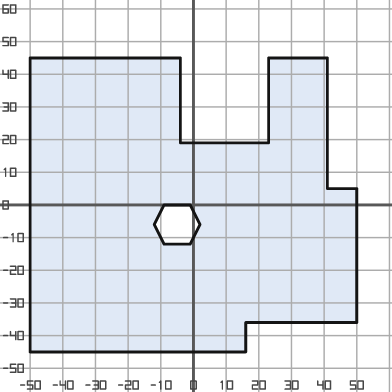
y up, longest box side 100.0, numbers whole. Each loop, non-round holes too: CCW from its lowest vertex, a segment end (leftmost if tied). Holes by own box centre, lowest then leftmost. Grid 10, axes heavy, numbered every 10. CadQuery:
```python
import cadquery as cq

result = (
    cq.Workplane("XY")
    .moveTo(-50.0, -45.0)
    .lineTo(16.0, -45.0)
    .lineTo(16.0, -36.0)
    .lineTo(50.0, -36.0)
    .lineTo(50.0, 5.0)
    .lineTo(41.0, 5.0)
    .lineTo(41.0, 45.0)
    .lineTo(23.0, 45.0)
    .lineTo(23.0, 19.0)
    .lineTo(-4.0, 19.0)
    .lineTo(-4.0, 45.0)
    .lineTo(-50.0, 45.0)
    .close()
    .moveTo(-9.0, -12.0)
    .lineTo(-1.0, -12.0)
    .lineTo(2.0, -6.0)
    .lineTo(-1.0, 0.0)
    .lineTo(-9.0, 0.0)
    .lineTo(-12.0, -6.0)
    .close()
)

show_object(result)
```